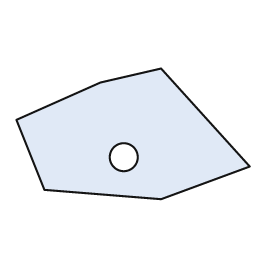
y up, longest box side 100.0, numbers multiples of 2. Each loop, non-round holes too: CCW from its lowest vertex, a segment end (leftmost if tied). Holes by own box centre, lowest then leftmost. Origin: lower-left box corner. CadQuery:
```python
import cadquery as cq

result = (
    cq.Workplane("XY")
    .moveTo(62.0, 0.0)
    .lineTo(100.0, 14.0)
    .lineTo(62.0, 56.0)
    .lineTo(36.0, 50.0)
    .lineTo(0.0, 34.0)
    .lineTo(12.0, 4.0)
    .close()
    .moveTo(46.0, 18.0)
    .circle(6.0)
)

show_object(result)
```